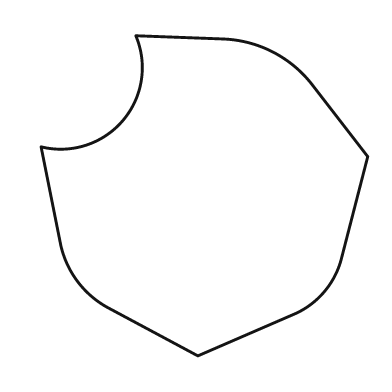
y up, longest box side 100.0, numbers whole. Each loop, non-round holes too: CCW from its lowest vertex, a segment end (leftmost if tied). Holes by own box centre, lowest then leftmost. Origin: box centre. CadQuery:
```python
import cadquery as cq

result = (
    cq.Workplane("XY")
    .moveTo(-2.0, -49.0)
    .lineTo(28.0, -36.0)
    .threePointArc((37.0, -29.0), (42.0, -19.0))
    .lineTo(50.0, 12.0)
    .lineTo(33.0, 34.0)
    .threePointArc((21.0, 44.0), (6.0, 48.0))
    .lineTo(-21.0, 49.0)
    .threePointArc((-25.0, 23.0), (-50.0, 15.0))
    .lineTo(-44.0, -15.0)
    .threePointArc((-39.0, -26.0), (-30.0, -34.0))
    .close()
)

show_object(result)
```